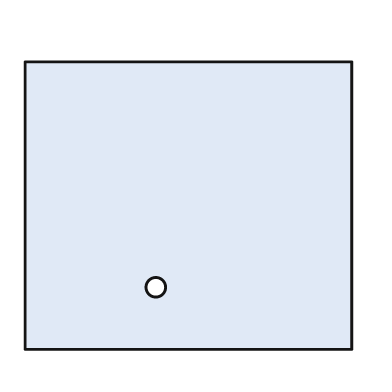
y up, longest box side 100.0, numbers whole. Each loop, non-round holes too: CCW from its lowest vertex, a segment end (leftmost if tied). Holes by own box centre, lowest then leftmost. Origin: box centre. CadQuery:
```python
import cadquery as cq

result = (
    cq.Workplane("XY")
    .moveTo(-50.0, -44.0)
    .lineTo(50.0, -44.0)
    .lineTo(50.0, 44.0)
    .lineTo(-50.0, 44.0)
    .close()
    .moveTo(-10.0, -25.0)
    .circle(3.0)
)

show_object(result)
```